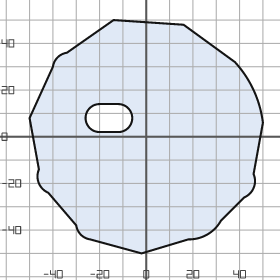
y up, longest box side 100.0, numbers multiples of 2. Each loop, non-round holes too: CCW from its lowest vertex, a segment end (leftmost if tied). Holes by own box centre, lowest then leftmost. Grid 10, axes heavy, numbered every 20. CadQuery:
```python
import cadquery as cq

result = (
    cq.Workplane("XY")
    .moveTo(-2.0, -50.0)
    .lineTo(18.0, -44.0)
    .threePointArc((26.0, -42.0), (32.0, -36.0))
    .lineTo(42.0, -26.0)
    .threePointArc((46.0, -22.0), (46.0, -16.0))
    .lineTo(50.0, 6.0)
    .threePointArc((46.0, 20.0), (38.0, 32.0))
    .lineTo(16.0, 48.0)
    .lineTo(-14.0, 50.0)
    .lineTo(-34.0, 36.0)
    .threePointArc((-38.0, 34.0), (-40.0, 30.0))
    .lineTo(-50.0, 8.0)
    .lineTo(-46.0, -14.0)
    .threePointArc((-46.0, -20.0), (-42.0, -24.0))
    .lineTo(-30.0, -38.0)
    .threePointArc((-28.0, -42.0), (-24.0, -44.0))
    .close()
    .moveTo(-20.0, 2.0)
    .lineTo(-12.0, 2.0)
    .threePointArc((-6.0, 8.0), (-12.0, 14.0))
    .lineTo(-20.0, 14.0)
    .threePointArc((-26.0, 8.0), (-20.0, 2.0))
    .close()
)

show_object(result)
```